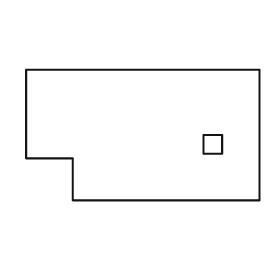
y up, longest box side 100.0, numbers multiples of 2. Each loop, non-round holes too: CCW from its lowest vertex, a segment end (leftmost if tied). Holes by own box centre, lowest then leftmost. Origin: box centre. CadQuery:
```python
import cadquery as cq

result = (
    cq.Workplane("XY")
    .moveTo(-30.0, -28.0)
    .lineTo(50.0, -28.0)
    .lineTo(50.0, 28.0)
    .lineTo(-50.0, 28.0)
    .lineTo(-50.0, -10.0)
    .lineTo(-30.0, -10.0)
    .close()
    .moveTo(26.0, -8.0)
    .lineTo(34.0, -8.0)
    .lineTo(34.0, 0.0)
    .lineTo(26.0, 0.0)
    .close()
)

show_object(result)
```